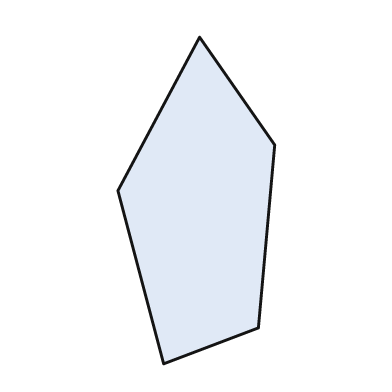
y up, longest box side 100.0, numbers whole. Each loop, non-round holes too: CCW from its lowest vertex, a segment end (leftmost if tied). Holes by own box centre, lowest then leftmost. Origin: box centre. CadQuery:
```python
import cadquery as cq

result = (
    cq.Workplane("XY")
    .moveTo(-10.0, -50.0)
    .lineTo(19.0, -39.0)
    .lineTo(24.0, 17.0)
    .lineTo(1.0, 50.0)
    .lineTo(-24.0, 3.0)
    .close()
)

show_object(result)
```